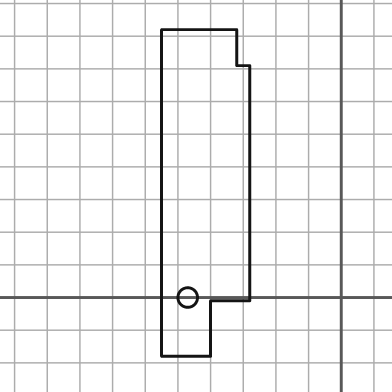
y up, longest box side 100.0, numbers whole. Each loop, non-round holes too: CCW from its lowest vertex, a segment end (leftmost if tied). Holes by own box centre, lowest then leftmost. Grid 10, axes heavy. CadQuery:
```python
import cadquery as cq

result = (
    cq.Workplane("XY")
    .moveTo(-55.0, -18.0)
    .lineTo(-40.0, -18.0)
    .lineTo(-40.0, -1.0)
    .lineTo(-28.0, -1.0)
    .lineTo(-28.0, 71.0)
    .lineTo(-32.0, 71.0)
    .lineTo(-32.0, 82.0)
    .lineTo(-55.0, 82.0)
    .close()
    .moveTo(-47.0, 0.0)
    .circle(3.0)
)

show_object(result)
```